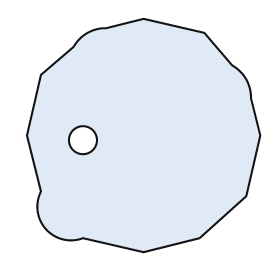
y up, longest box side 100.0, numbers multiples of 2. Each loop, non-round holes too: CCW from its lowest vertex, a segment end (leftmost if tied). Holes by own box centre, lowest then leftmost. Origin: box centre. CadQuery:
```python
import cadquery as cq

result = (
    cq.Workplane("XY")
    .moveTo(0.0, -50.0)
    .lineTo(24.0, -44.0)
    .lineTo(44.0, -26.0)
    .lineTo(50.0, 0.0)
    .lineTo(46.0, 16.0)
    .threePointArc((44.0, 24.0), (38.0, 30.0))
    .lineTo(26.0, 44.0)
    .lineTo(0.0, 50.0)
    .lineTo(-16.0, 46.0)
    .threePointArc((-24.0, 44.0), (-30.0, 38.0))
    .lineTo(-44.0, 26.0)
    .lineTo(-50.0, 0.0)
    .lineTo(-44.0, -24.0)
    .threePointArc((-42.0, -40.0), (-26.0, -44.0))
    .close()
    .moveTo(-26.0, -2.0)
    .circle(6.0)
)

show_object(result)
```